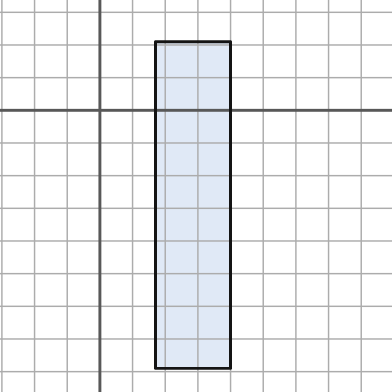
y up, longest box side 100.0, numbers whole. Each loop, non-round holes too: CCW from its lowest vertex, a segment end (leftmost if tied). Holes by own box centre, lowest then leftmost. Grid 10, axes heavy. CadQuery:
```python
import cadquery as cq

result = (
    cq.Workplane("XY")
    .moveTo(17.0, -79.0)
    .lineTo(40.0, -79.0)
    .lineTo(40.0, 21.0)
    .lineTo(17.0, 21.0)
    .close()
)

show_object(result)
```